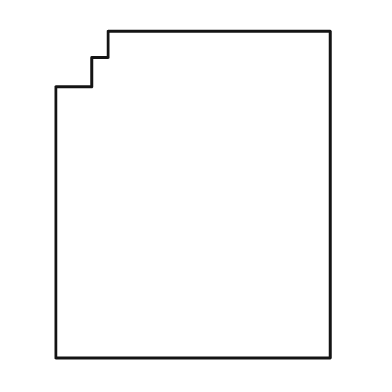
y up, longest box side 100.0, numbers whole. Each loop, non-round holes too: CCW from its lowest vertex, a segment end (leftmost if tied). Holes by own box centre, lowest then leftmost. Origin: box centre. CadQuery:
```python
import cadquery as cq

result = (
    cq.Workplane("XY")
    .moveTo(-42.0, -50.0)
    .lineTo(42.0, -50.0)
    .lineTo(42.0, 50.0)
    .lineTo(-26.0, 50.0)
    .lineTo(-26.0, 42.0)
    .lineTo(-31.0, 42.0)
    .lineTo(-31.0, 33.0)
    .lineTo(-42.0, 33.0)
    .close()
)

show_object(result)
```